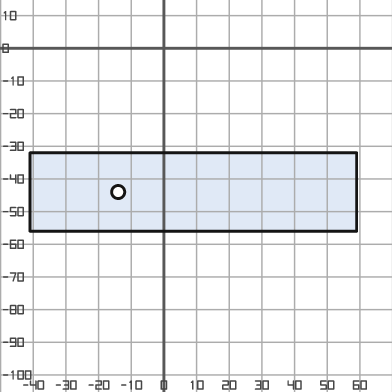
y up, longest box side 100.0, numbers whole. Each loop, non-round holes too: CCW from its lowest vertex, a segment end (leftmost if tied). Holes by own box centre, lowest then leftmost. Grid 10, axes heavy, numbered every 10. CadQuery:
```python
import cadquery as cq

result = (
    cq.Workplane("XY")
    .moveTo(-41.0, -56.0)
    .lineTo(59.0, -56.0)
    .lineTo(59.0, -32.0)
    .lineTo(-41.0, -32.0)
    .close()
    .moveTo(-14.0, -44.0)
    .circle(2.0)
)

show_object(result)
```